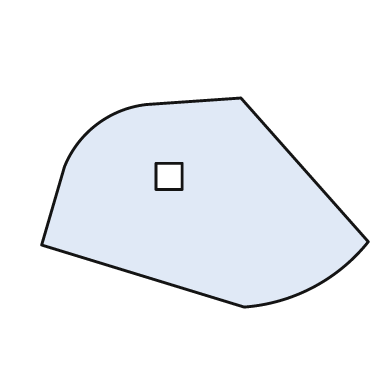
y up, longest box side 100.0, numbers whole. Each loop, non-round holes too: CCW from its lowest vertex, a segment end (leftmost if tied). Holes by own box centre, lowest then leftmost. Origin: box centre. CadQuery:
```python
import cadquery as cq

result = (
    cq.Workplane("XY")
    .moveTo(12.0, -32.0)
    .threePointArc((33.0, -26.0), (50.0, -12.0))
    .lineTo(11.0, 32.0)
    .lineTo(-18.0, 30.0)
    .threePointArc((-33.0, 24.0), (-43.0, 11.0))
    .lineTo(-50.0, -13.0)
    .close()
    .moveTo(-15.0, 4.0)
    .lineTo(-7.0, 4.0)
    .lineTo(-7.0, 12.0)
    .lineTo(-15.0, 12.0)
    .close()
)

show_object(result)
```